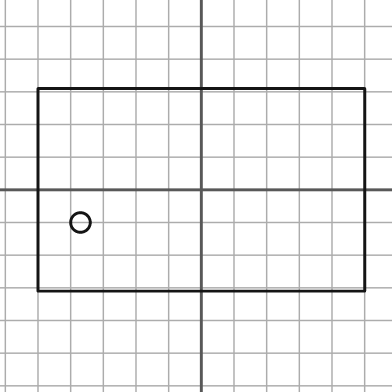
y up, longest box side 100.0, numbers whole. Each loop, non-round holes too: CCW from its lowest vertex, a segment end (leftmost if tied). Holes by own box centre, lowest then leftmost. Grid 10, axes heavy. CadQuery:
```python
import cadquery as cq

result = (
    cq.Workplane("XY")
    .moveTo(-50.0, -31.0)
    .lineTo(50.0, -31.0)
    .lineTo(50.0, 31.0)
    .lineTo(-50.0, 31.0)
    .close()
    .moveTo(-37.0, -10.0)
    .circle(3.0)
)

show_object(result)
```